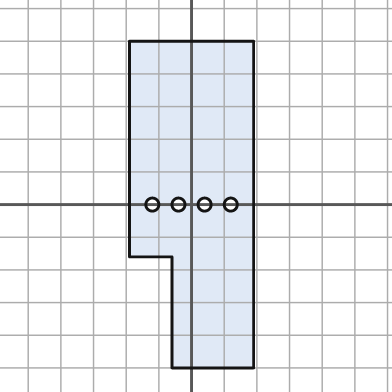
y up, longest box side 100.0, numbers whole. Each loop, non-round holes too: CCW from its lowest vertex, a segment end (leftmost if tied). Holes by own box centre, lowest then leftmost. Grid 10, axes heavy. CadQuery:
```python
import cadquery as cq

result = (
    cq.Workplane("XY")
    .moveTo(-6.0, -50.0)
    .lineTo(19.0, -50.0)
    .lineTo(19.0, 50.0)
    .lineTo(-19.0, 50.0)
    .lineTo(-19.0, -16.0)
    .lineTo(-6.0, -16.0)
    .close()
    .moveTo(-12.0, 0.0)
    .circle(2.0)
    .moveTo(-4.0, 0.0)
    .circle(2.0)
    .moveTo(4.0, 0.0)
    .circle(2.0)
    .moveTo(12.0, 0.0)
    .circle(2.0)
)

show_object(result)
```